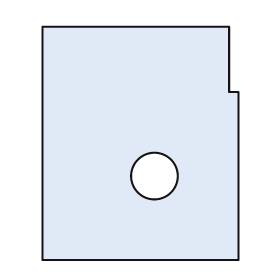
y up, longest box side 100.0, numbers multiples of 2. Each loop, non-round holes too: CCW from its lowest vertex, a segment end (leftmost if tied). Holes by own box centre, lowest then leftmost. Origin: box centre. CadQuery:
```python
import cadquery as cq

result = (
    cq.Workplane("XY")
    .moveTo(-42.0, -50.0)
    .lineTo(42.0, -50.0)
    .lineTo(42.0, 22.0)
    .lineTo(38.0, 22.0)
    .lineTo(38.0, 50.0)
    .lineTo(-42.0, 50.0)
    .close()
    .moveTo(6.0, -14.0)
    .circle(10.0)
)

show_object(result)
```